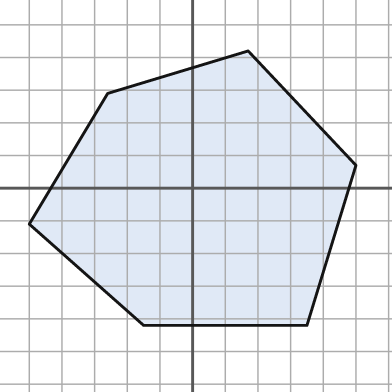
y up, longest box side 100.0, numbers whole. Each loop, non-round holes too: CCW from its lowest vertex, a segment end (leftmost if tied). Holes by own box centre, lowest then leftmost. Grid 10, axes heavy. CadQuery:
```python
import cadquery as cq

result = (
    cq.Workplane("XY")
    .moveTo(-15.0, -42.0)
    .lineTo(35.0, -42.0)
    .lineTo(50.0, 7.0)
    .lineTo(17.0, 42.0)
    .lineTo(-26.0, 29.0)
    .lineTo(-50.0, -11.0)
    .close()
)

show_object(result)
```